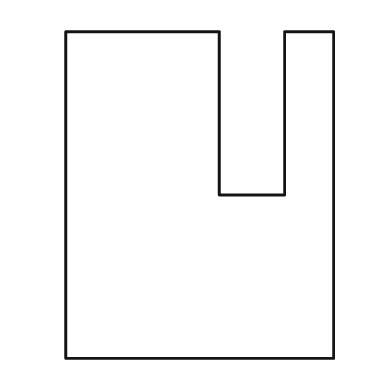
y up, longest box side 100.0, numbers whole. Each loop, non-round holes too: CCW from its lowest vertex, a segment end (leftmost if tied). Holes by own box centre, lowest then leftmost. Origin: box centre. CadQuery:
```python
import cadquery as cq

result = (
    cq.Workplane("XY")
    .moveTo(-41.0, -50.0)
    .lineTo(41.0, -50.0)
    .lineTo(41.0, 50.0)
    .lineTo(26.0, 50.0)
    .lineTo(26.0, 0.0)
    .lineTo(6.0, 0.0)
    .lineTo(6.0, 50.0)
    .lineTo(-41.0, 50.0)
    .close()
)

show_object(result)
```